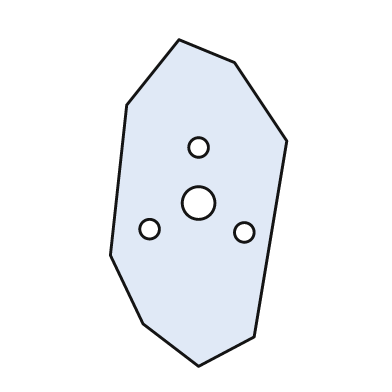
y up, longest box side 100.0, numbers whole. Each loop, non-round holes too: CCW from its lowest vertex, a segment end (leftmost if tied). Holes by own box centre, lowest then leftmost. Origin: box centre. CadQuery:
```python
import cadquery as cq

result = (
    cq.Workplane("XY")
    .moveTo(0.0, -50.0)
    .lineTo(17.0, -41.0)
    .lineTo(27.0, 19.0)
    .lineTo(11.0, 43.0)
    .lineTo(-6.0, 50.0)
    .lineTo(-22.0, 30.0)
    .lineTo(-27.0, -16.0)
    .lineTo(-17.0, -37.0)
    .close()
    .moveTo(14.0, -9.0)
    .circle(3.0)
    .moveTo(-15.0, -8.0)
    .circle(3.0)
    .moveTo(0.0, 0.0)
    .circle(5.0)
    .moveTo(0.0, 17.0)
    .circle(3.0)
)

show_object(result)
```